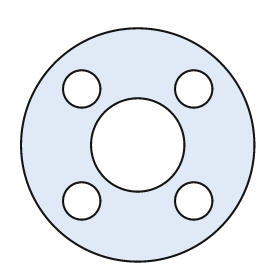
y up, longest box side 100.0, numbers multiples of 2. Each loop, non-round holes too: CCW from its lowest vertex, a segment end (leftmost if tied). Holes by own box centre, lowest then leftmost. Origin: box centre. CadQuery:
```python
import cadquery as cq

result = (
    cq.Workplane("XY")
    .moveTo(0.0, 0.0)
    .circle(50.0)
    .moveTo(-24.0, -24.0)
    .circle(8.0)
    .moveTo(24.0, -24.0)
    .circle(8.0)
    .moveTo(0.0, 0.0)
    .circle(20.0)
    .moveTo(-24.0, 24.0)
    .circle(8.0)
    .moveTo(24.0, 24.0)
    .circle(8.0)
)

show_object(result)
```